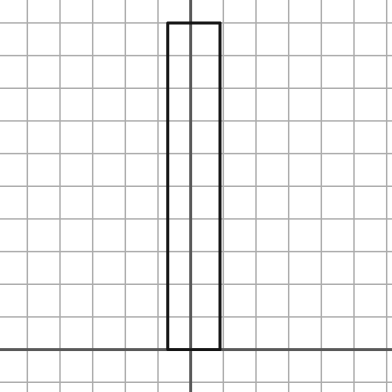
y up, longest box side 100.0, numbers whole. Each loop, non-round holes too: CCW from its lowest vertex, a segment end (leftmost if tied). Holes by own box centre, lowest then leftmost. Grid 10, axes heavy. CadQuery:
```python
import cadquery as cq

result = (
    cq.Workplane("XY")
    .moveTo(-7.0, 0.0)
    .lineTo(9.0, 0.0)
    .lineTo(9.0, 100.0)
    .lineTo(-7.0, 100.0)
    .close()
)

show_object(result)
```